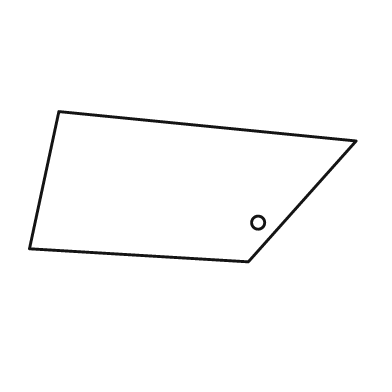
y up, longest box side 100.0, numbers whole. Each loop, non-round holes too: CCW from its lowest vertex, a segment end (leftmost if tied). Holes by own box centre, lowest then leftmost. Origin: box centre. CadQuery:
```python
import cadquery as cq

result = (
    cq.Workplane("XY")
    .moveTo(17.0, -23.0)
    .lineTo(50.0, 14.0)
    .lineTo(-41.0, 23.0)
    .lineTo(-50.0, -19.0)
    .close()
    .moveTo(20.0, -11.0)
    .circle(2.0)
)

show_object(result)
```